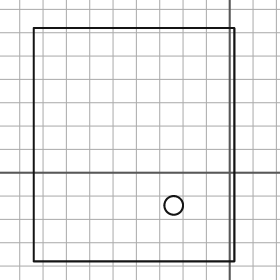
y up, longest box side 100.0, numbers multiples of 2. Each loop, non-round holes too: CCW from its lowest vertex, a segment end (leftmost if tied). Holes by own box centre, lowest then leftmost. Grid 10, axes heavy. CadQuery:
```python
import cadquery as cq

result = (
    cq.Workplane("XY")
    .moveTo(-84.0, -38.0)
    .lineTo(2.0, -38.0)
    .lineTo(2.0, 62.0)
    .lineTo(-84.0, 62.0)
    .close()
    .moveTo(-24.0, -14.0)
    .circle(4.0)
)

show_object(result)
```